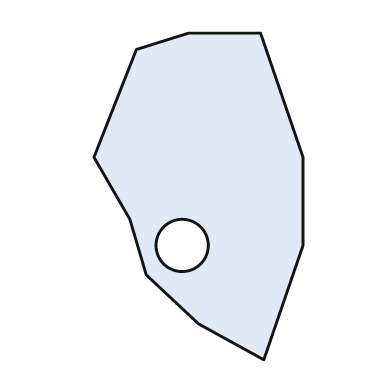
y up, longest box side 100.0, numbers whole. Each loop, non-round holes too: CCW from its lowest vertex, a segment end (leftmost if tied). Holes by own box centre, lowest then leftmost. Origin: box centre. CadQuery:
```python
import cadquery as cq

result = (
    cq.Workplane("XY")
    .moveTo(20.0, -50.0)
    .lineTo(32.0, -15.0)
    .lineTo(32.0, 12.0)
    .lineTo(19.0, 50.0)
    .lineTo(-3.0, 50.0)
    .lineTo(-19.0, 45.0)
    .lineTo(-32.0, 12.0)
    .lineTo(-21.0, -7.0)
    .lineTo(-16.0, -24.0)
    .lineTo(0.0, -39.0)
    .close()
    .moveTo(-5.0, -15.0)
    .circle(8.0)
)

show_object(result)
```